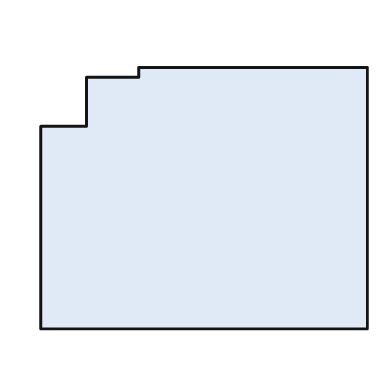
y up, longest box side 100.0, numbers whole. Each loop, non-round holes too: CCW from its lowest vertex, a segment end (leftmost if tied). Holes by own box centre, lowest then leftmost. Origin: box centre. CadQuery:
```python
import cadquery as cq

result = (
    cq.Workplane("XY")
    .moveTo(-50.0, -40.0)
    .lineTo(50.0, -40.0)
    .lineTo(50.0, 40.0)
    .lineTo(-20.0, 40.0)
    .lineTo(-20.0, 37.0)
    .lineTo(-36.0, 37.0)
    .lineTo(-36.0, 22.0)
    .lineTo(-50.0, 22.0)
    .close()
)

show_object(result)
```